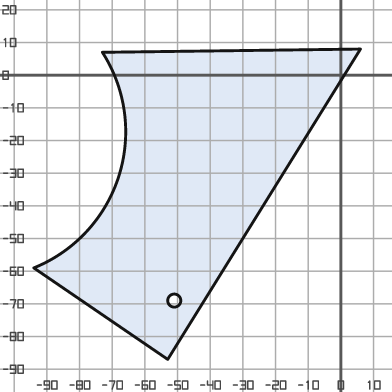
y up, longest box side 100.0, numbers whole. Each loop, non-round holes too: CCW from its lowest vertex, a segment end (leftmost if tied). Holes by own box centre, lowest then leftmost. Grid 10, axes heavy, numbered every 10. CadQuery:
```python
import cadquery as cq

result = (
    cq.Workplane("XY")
    .moveTo(-53.0, -87.0)
    .lineTo(6.0, 8.0)
    .lineTo(-73.0, 7.0)
    .threePointArc((-68.0, -31.0), (-94.0, -59.0))
    .close()
    .moveTo(-51.0, -69.0)
    .circle(2.0)
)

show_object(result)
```